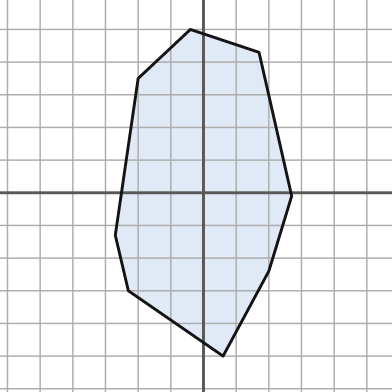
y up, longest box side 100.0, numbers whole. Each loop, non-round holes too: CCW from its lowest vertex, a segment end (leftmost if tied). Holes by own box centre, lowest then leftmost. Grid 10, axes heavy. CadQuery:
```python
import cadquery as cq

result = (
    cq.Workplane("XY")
    .moveTo(6.0, -50.0)
    .lineTo(20.0, -24.0)
    .lineTo(27.0, -1.0)
    .lineTo(17.0, 43.0)
    .lineTo(-4.0, 50.0)
    .lineTo(-20.0, 35.0)
    .lineTo(-27.0, -13.0)
    .lineTo(-23.0, -30.0)
    .close()
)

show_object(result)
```